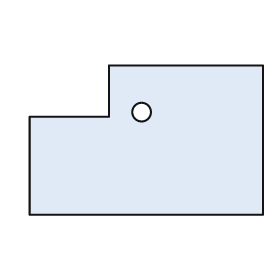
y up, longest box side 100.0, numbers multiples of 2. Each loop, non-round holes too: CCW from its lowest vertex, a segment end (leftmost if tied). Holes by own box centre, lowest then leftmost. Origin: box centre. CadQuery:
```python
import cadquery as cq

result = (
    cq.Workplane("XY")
    .moveTo(-50.0, -32.0)
    .lineTo(50.0, -32.0)
    .lineTo(50.0, 32.0)
    .lineTo(-16.0, 32.0)
    .lineTo(-16.0, 10.0)
    .lineTo(-50.0, 10.0)
    .close()
    .moveTo(-2.0, 12.0)
    .circle(4.0)
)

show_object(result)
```